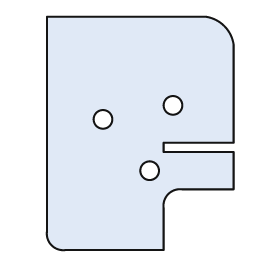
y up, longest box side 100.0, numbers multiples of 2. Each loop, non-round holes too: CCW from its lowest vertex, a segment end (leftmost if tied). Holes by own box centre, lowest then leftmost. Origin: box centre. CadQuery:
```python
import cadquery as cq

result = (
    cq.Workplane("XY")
    .moveTo(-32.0, -50.0)
    .lineTo(10.0, -50.0)
    .lineTo(10.0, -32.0)
    .threePointArc((12.0, -26.0), (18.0, -24.0))
    .lineTo(40.0, -24.0)
    .lineTo(40.0, -8.0)
    .lineTo(10.0, -8.0)
    .lineTo(10.0, -4.0)
    .lineTo(40.0, -4.0)
    .lineTo(40.0, 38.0)
    .threePointArc((36.0, 46.0), (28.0, 50.0))
    .lineTo(-40.0, 50.0)
    .lineTo(-40.0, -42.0)
    .threePointArc((-38.0, -48.0), (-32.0, -50.0))
    .close()
    .moveTo(4.0, -16.0)
    .circle(4.0)
    .moveTo(-16.0, 6.0)
    .circle(4.0)
    .moveTo(14.0, 12.0)
    .circle(4.0)
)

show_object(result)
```